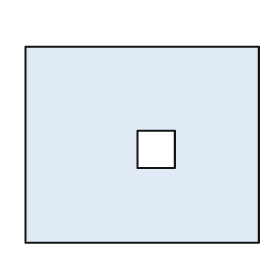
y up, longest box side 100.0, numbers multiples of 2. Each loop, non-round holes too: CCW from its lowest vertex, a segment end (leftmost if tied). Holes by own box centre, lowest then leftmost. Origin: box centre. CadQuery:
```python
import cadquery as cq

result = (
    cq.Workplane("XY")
    .moveTo(-50.0, -42.0)
    .lineTo(50.0, -42.0)
    .lineTo(50.0, 42.0)
    .lineTo(-50.0, 42.0)
    .close()
    .moveTo(-2.0, -10.0)
    .lineTo(14.0, -10.0)
    .lineTo(14.0, 6.0)
    .lineTo(-2.0, 6.0)
    .close()
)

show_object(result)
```